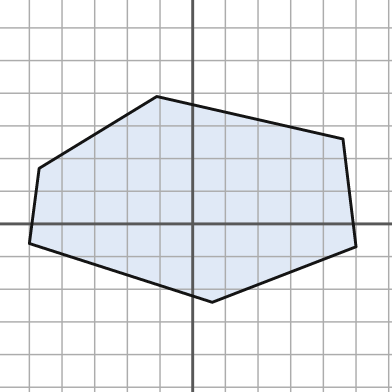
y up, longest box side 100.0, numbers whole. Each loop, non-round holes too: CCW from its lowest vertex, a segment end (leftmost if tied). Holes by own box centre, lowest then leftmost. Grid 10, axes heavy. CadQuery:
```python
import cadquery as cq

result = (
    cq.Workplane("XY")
    .moveTo(6.0, -24.0)
    .lineTo(50.0, -7.0)
    .lineTo(46.0, 26.0)
    .lineTo(-11.0, 39.0)
    .lineTo(-47.0, 17.0)
    .lineTo(-50.0, -6.0)
    .close()
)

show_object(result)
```